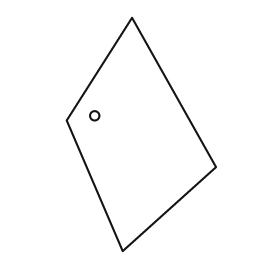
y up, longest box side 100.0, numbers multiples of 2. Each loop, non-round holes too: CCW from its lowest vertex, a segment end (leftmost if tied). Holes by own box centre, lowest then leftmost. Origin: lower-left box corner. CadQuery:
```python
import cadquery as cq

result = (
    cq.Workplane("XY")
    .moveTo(24.0, 0.0)
    .lineTo(64.0, 36.0)
    .lineTo(28.0, 100.0)
    .lineTo(0.0, 56.0)
    .close()
    .moveTo(12.0, 58.0)
    .circle(2.0)
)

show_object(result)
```